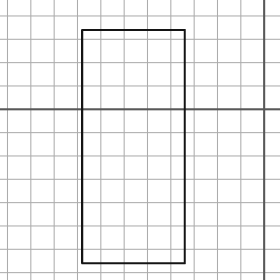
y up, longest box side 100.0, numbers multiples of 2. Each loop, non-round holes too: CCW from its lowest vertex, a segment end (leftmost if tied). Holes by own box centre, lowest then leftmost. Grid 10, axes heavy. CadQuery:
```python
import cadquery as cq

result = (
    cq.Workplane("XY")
    .moveTo(-78.0, -66.0)
    .lineTo(-34.0, -66.0)
    .lineTo(-34.0, 34.0)
    .lineTo(-78.0, 34.0)
    .close()
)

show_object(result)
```